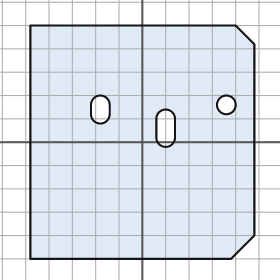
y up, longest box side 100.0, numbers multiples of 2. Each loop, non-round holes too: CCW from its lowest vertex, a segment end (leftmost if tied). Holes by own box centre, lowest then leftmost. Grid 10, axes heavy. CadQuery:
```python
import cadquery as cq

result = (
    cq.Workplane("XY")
    .moveTo(-48.0, -50.0)
    .lineTo(38.0, -50.0)
    .lineTo(48.0, -40.0)
    .lineTo(48.0, 42.0)
    .lineTo(40.0, 50.0)
    .lineTo(-48.0, 50.0)
    .close()
    .moveTo(6.0, 2.0)
    .threePointArc((10.0, -2.0), (14.0, 2.0))
    .lineTo(14.0, 10.0)
    .threePointArc((10.0, 14.0), (6.0, 10.0))
    .close()
    .moveTo(-22.0, 12.0)
    .threePointArc((-18.0, 8.0), (-14.0, 12.0))
    .lineTo(-14.0, 16.0)
    .threePointArc((-18.0, 20.0), (-22.0, 16.0))
    .close()
    .moveTo(36.0, 16.0)
    .circle(4.0)
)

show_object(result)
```